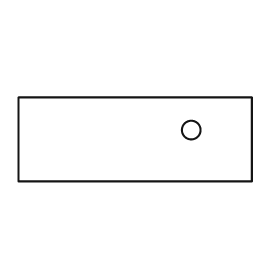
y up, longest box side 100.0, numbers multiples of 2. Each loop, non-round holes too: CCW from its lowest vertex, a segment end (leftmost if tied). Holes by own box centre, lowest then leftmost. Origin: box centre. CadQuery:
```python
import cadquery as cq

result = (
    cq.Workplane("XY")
    .moveTo(-50.0, -18.0)
    .lineTo(50.0, -18.0)
    .lineTo(50.0, 18.0)
    .lineTo(-50.0, 18.0)
    .close()
    .moveTo(24.0, 4.0)
    .circle(4.0)
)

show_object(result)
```